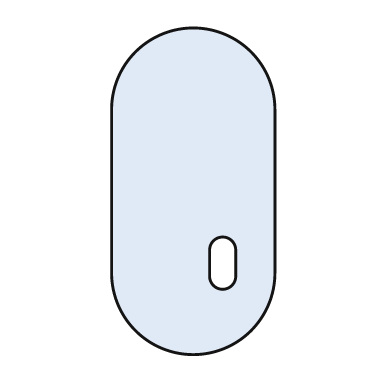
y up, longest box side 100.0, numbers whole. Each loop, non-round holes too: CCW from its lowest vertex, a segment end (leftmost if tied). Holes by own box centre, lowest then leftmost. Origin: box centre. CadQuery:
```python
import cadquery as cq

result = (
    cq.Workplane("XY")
    .moveTo(-25.0, -25.0)
    .threePointArc((0.0, -50.0), (25.0, -25.0))
    .lineTo(25.0, 25.0)
    .threePointArc((0.0, 50.0), (-25.0, 25.0))
    .close()
    .moveTo(5.0, -26.0)
    .threePointArc((9.0, -30.0), (13.0, -26.0))
    .lineTo(13.0, -18.0)
    .threePointArc((9.0, -14.0), (5.0, -18.0))
    .close()
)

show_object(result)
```